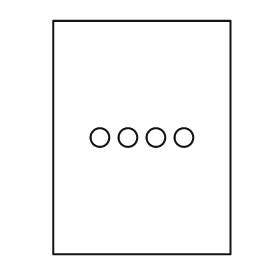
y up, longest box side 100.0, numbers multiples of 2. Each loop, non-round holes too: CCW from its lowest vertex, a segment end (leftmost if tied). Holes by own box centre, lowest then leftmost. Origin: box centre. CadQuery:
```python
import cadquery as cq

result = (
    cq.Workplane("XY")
    .moveTo(-38.0, -50.0)
    .lineTo(38.0, -50.0)
    .lineTo(38.0, 50.0)
    .lineTo(-38.0, 50.0)
    .close()
    .moveTo(-18.0, 0.0)
    .circle(4.0)
    .moveTo(-6.0, 0.0)
    .circle(4.0)
    .moveTo(6.0, 0.0)
    .circle(4.0)
    .moveTo(18.0, 0.0)
    .circle(4.0)
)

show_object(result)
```